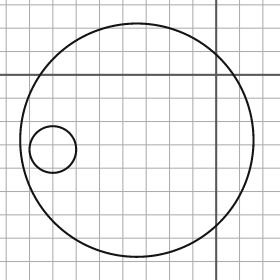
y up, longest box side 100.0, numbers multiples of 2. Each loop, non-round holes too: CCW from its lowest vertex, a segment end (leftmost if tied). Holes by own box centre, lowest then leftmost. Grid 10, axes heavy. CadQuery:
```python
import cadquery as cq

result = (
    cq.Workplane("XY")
    .moveTo(-34.0, -28.0)
    .circle(50.0)
    .moveTo(-70.0, -32.0)
    .circle(10.0)
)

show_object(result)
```